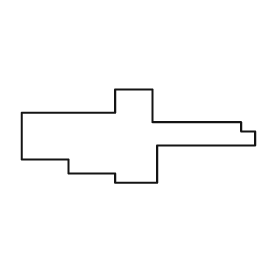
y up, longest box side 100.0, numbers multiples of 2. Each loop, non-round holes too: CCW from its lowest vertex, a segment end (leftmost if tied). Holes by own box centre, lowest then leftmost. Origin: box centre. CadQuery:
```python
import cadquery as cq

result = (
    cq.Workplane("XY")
    .moveTo(-10.0, -20.0)
    .lineTo(8.0, -20.0)
    .lineTo(8.0, -4.0)
    .lineTo(50.0, -4.0)
    .lineTo(50.0, 2.0)
    .lineTo(44.0, 2.0)
    .lineTo(44.0, 6.0)
    .lineTo(6.0, 6.0)
    .lineTo(6.0, 20.0)
    .lineTo(-10.0, 20.0)
    .lineTo(-10.0, 10.0)
    .lineTo(-50.0, 10.0)
    .lineTo(-50.0, -10.0)
    .lineTo(-30.0, -10.0)
    .lineTo(-30.0, -16.0)
    .lineTo(-10.0, -16.0)
    .close()
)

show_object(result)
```